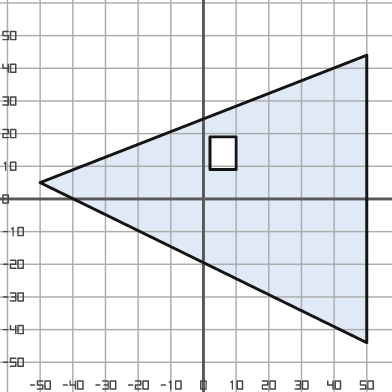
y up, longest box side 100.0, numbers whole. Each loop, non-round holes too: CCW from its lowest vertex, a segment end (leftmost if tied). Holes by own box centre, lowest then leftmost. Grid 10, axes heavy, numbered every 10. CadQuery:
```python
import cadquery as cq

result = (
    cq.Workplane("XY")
    .moveTo(50.0, -44.0)
    .lineTo(50.0, 44.0)
    .lineTo(-50.0, 5.0)
    .close()
    .moveTo(2.0, 9.0)
    .lineTo(10.0, 9.0)
    .lineTo(10.0, 19.0)
    .lineTo(2.0, 19.0)
    .close()
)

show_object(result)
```